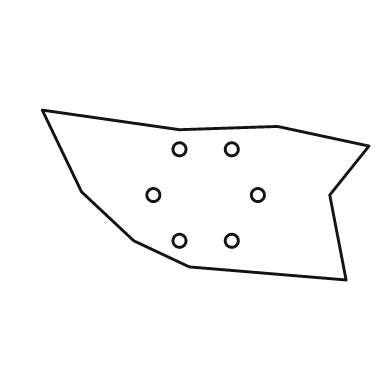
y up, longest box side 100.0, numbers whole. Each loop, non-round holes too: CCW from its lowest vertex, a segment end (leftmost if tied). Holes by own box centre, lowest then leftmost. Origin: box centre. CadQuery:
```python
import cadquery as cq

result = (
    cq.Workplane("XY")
    .moveTo(43.0, -26.0)
    .lineTo(38.0, 0.0)
    .lineTo(50.0, 15.0)
    .lineTo(22.0, 21.0)
    .lineTo(-8.0, 20.0)
    .lineTo(-50.0, 26.0)
    .lineTo(-38.0, 1.0)
    .lineTo(-22.0, -14.0)
    .lineTo(-5.0, -22.0)
    .close()
    .moveTo(-8.0, -14.0)
    .circle(2.0)
    .moveTo(8.0, -14.0)
    .circle(2.0)
    .moveTo(-16.0, 0.0)
    .circle(2.0)
    .moveTo(16.0, 0.0)
    .circle(2.0)
    .moveTo(-8.0, 14.0)
    .circle(2.0)
    .moveTo(8.0, 14.0)
    .circle(2.0)
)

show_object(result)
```